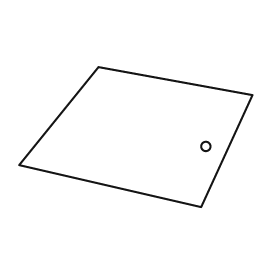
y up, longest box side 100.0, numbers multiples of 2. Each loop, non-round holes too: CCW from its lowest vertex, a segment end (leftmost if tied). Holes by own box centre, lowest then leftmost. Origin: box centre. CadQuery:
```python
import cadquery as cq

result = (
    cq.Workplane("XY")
    .moveTo(28.0, -30.0)
    .lineTo(50.0, 18.0)
    .lineTo(-16.0, 30.0)
    .lineTo(-50.0, -12.0)
    .close()
    .moveTo(30.0, -4.0)
    .circle(2.0)
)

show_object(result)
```